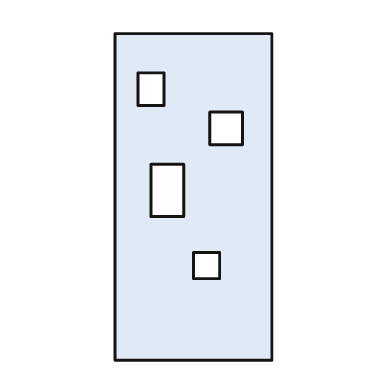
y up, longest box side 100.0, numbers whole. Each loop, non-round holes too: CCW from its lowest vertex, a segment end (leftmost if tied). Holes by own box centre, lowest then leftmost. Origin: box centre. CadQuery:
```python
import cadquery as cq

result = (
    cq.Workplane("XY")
    .moveTo(-24.0, -50.0)
    .lineTo(24.0, -50.0)
    .lineTo(24.0, 50.0)
    .lineTo(-24.0, 50.0)
    .close()
    .moveTo(0.0, -25.0)
    .lineTo(8.0, -25.0)
    .lineTo(8.0, -17.0)
    .lineTo(0.0, -17.0)
    .close()
    .moveTo(-13.0, -6.0)
    .lineTo(-3.0, -6.0)
    .lineTo(-3.0, 10.0)
    .lineTo(-13.0, 10.0)
    .close()
    .moveTo(5.0, 16.0)
    .lineTo(15.0, 16.0)
    .lineTo(15.0, 26.0)
    .lineTo(5.0, 26.0)
    .close()
    .moveTo(-17.0, 28.0)
    .lineTo(-9.0, 28.0)
    .lineTo(-9.0, 38.0)
    .lineTo(-17.0, 38.0)
    .close()
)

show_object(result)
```